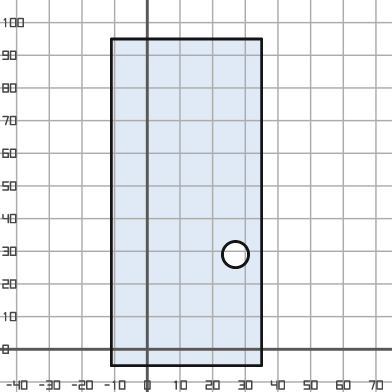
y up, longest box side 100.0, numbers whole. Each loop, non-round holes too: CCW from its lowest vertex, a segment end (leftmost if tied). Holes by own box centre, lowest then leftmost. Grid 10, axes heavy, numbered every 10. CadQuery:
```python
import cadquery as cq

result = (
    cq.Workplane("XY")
    .moveTo(-11.0, -5.0)
    .lineTo(35.0, -5.0)
    .lineTo(35.0, 95.0)
    .lineTo(-11.0, 95.0)
    .close()
    .moveTo(27.0, 29.0)
    .circle(4.0)
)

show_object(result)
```